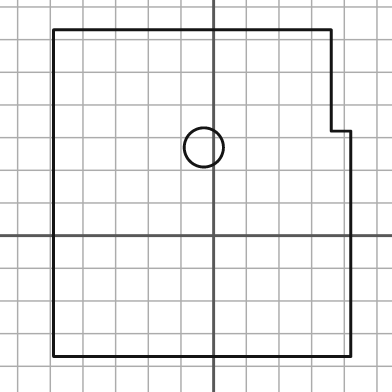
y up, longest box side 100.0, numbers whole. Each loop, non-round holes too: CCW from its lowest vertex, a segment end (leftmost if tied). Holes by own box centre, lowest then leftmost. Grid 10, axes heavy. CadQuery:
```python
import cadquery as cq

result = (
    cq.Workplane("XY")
    .moveTo(-49.0, -37.0)
    .lineTo(42.0, -37.0)
    .lineTo(42.0, 32.0)
    .lineTo(36.0, 32.0)
    .lineTo(36.0, 63.0)
    .lineTo(-49.0, 63.0)
    .close()
    .moveTo(-3.0, 27.0)
    .circle(6.0)
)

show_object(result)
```